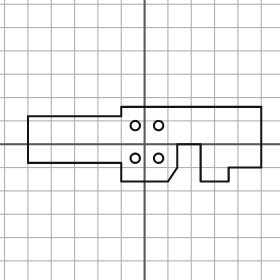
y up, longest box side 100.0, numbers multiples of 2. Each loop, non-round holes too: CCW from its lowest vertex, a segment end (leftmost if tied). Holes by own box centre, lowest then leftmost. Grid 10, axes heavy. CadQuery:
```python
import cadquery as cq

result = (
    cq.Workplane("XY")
    .moveTo(-10.0, -16.0)
    .lineTo(10.0, -16.0)
    .lineTo(14.0, -10.0)
    .lineTo(14.0, 0.0)
    .lineTo(24.0, 0.0)
    .lineTo(24.0, -16.0)
    .lineTo(36.0, -16.0)
    .lineTo(36.0, -10.0)
    .lineTo(50.0, -10.0)
    .lineTo(50.0, 16.0)
    .lineTo(-10.0, 16.0)
    .lineTo(-10.0, 12.0)
    .lineTo(-50.0, 12.0)
    .lineTo(-50.0, -8.0)
    .lineTo(-10.0, -8.0)
    .close()
    .moveTo(-4.0, -6.0)
    .circle(2.0)
    .moveTo(6.0, -6.0)
    .circle(2.0)
    .moveTo(-4.0, 8.0)
    .circle(2.0)
    .moveTo(6.0, 8.0)
    .circle(2.0)
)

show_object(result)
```